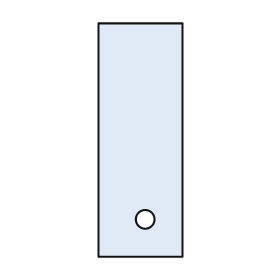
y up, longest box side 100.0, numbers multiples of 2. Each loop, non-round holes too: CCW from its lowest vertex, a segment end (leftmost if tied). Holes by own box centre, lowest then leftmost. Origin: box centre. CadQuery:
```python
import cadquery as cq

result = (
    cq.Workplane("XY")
    .moveTo(-18.0, -50.0)
    .lineTo(18.0, -50.0)
    .lineTo(18.0, 50.0)
    .lineTo(-18.0, 50.0)
    .close()
    .moveTo(2.0, -34.0)
    .circle(4.0)
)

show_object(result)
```